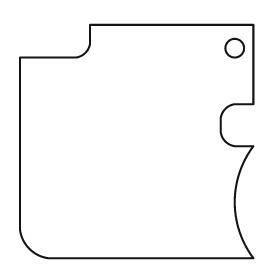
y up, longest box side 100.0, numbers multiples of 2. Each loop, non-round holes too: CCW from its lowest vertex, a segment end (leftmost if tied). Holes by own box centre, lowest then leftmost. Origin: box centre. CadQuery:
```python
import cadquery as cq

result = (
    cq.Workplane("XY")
    .moveTo(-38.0, -50.0)
    .lineTo(50.0, -50.0)
    .threePointArc((42.0, -26.0), (50.0, -2.0))
    .lineTo(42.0, -2.0)
    .threePointArc((38.0, 0.0), (36.0, 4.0))
    .lineTo(36.0, 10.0)
    .threePointArc((38.0, 14.0), (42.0, 16.0))
    .lineTo(50.0, 16.0)
    .lineTo(50.0, 50.0)
    .lineTo(-20.0, 50.0)
    .lineTo(-20.0, 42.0)
    .threePointArc((-22.0, 38.0), (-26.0, 36.0))
    .lineTo(-50.0, 36.0)
    .lineTo(-50.0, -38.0)
    .threePointArc((-46.0, -46.0), (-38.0, -50.0))
    .close()
    .moveTo(42.0, 40.0)
    .circle(4.0)
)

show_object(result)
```